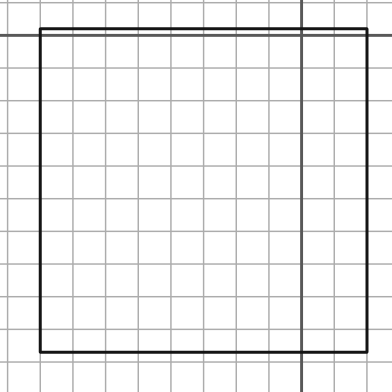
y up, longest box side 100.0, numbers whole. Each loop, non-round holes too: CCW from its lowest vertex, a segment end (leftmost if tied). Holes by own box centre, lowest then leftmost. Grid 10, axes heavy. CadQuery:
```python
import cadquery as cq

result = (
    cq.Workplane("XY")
    .moveTo(-80.0, -97.0)
    .lineTo(20.0, -97.0)
    .lineTo(20.0, 2.0)
    .lineTo(-80.0, 2.0)
    .close()
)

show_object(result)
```